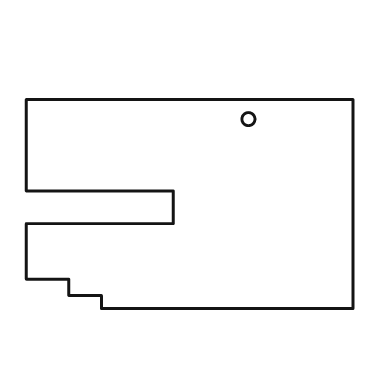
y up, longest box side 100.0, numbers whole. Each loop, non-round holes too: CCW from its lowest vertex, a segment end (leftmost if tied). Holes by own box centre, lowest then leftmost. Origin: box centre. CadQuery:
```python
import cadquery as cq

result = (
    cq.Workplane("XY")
    .moveTo(-27.0, -32.0)
    .lineTo(50.0, -32.0)
    .lineTo(50.0, 32.0)
    .lineTo(-50.0, 32.0)
    .lineTo(-50.0, 4.0)
    .lineTo(-5.0, 4.0)
    .lineTo(-5.0, -6.0)
    .lineTo(-50.0, -6.0)
    .lineTo(-50.0, -23.0)
    .lineTo(-37.0, -23.0)
    .lineTo(-37.0, -28.0)
    .lineTo(-27.0, -28.0)
    .close()
    .moveTo(18.0, 26.0)
    .circle(2.0)
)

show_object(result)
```